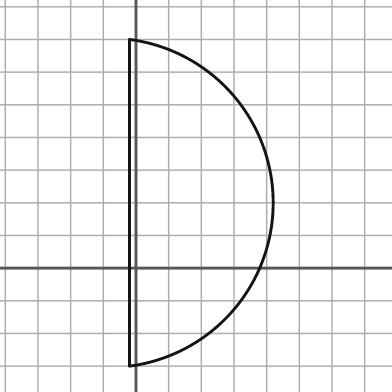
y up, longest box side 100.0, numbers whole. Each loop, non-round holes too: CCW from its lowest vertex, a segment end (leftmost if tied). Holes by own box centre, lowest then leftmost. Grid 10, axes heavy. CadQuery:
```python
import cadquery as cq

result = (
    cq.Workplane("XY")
    .moveTo(-2.0, -30.0)
    .threePointArc((42.0, 20.0), (-2.0, 70.0))
    .close()
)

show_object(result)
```